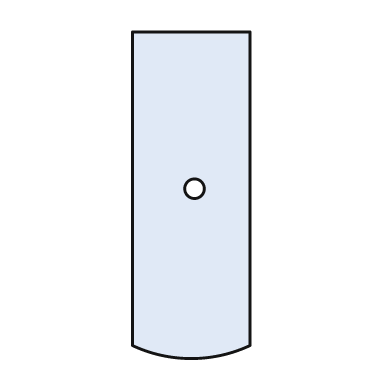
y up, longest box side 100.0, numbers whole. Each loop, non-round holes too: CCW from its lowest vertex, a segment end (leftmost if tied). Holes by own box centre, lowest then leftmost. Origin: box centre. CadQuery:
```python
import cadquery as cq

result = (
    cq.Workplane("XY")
    .moveTo(-18.0, -46.0)
    .threePointArc((0.0, -50.0), (18.0, -46.0))
    .lineTo(18.0, 50.0)
    .lineTo(-18.0, 50.0)
    .close()
    .moveTo(1.0, 2.0)
    .circle(3.0)
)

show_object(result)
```